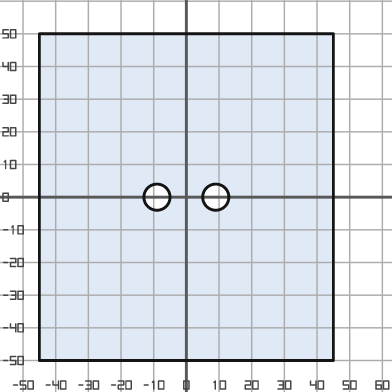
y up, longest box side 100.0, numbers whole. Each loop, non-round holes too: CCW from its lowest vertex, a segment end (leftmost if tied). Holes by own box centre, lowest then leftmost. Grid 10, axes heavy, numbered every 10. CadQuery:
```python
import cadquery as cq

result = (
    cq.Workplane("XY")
    .moveTo(-45.0, -50.0)
    .lineTo(45.0, -50.0)
    .lineTo(45.0, 50.0)
    .lineTo(-45.0, 50.0)
    .close()
    .moveTo(-9.0, 0.0)
    .circle(4.0)
    .moveTo(9.0, 0.0)
    .circle(4.0)
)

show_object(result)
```